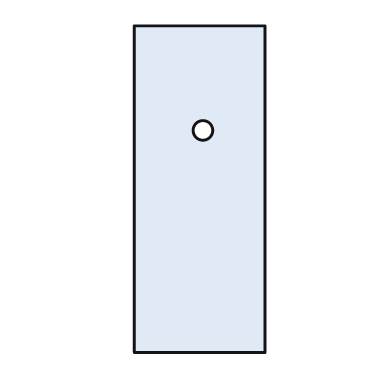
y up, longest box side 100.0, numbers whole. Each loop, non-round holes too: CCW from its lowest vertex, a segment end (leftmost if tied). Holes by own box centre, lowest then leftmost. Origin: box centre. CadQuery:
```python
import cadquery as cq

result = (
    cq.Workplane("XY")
    .moveTo(-20.0, -50.0)
    .lineTo(20.0, -50.0)
    .lineTo(20.0, 50.0)
    .lineTo(-20.0, 50.0)
    .close()
    .moveTo(1.0, 18.0)
    .circle(3.0)
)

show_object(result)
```